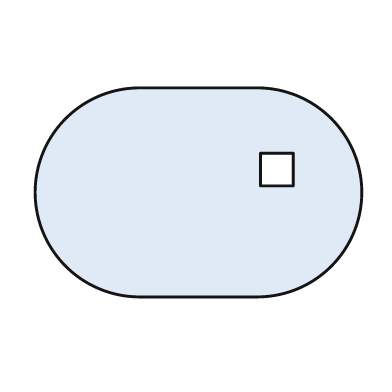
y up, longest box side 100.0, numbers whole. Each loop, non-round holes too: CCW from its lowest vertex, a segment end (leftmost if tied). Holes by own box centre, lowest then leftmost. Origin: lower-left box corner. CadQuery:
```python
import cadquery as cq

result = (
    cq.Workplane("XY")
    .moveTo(32.0, 0.0)
    .lineTo(68.0, 0.0)
    .threePointArc((100.0, 32.0), (68.0, 64.0))
    .lineTo(32.0, 64.0)
    .threePointArc((0.0, 32.0), (32.0, 0.0))
    .close()
    .moveTo(69.0, 34.0)
    .lineTo(79.0, 34.0)
    .lineTo(79.0, 44.0)
    .lineTo(69.0, 44.0)
    .close()
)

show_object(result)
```